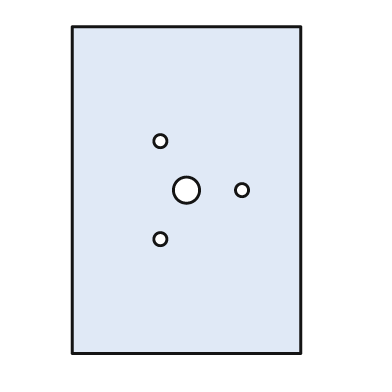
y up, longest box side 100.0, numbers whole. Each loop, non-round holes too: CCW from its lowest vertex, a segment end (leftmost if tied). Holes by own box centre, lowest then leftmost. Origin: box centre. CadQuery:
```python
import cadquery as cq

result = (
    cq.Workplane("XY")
    .moveTo(-35.0, -50.0)
    .lineTo(35.0, -50.0)
    .lineTo(35.0, 50.0)
    .lineTo(-35.0, 50.0)
    .close()
    .moveTo(-8.0, -15.0)
    .circle(2.0)
    .moveTo(0.0, 0.0)
    .circle(4.0)
    .moveTo(17.0, 0.0)
    .circle(2.0)
    .moveTo(-8.0, 15.0)
    .circle(2.0)
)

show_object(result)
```